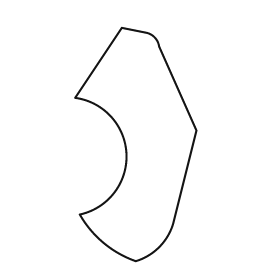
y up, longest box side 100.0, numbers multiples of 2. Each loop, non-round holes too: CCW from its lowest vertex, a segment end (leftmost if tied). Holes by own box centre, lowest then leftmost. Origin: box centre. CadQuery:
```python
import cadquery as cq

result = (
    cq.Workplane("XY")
    .moveTo(0.0, -50.0)
    .threePointArc((10.0, -44.0), (16.0, -34.0))
    .lineTo(26.0, 6.0)
    .lineTo(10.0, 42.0)
    .threePointArc((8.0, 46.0), (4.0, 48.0))
    .lineTo(-6.0, 50.0)
    .lineTo(-26.0, 20.0)
    .threePointArc((-4.0, -4.0), (-24.0, -30.0))
    .threePointArc((-14.0, -42.0), (0.0, -50.0))
    .close()
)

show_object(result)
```